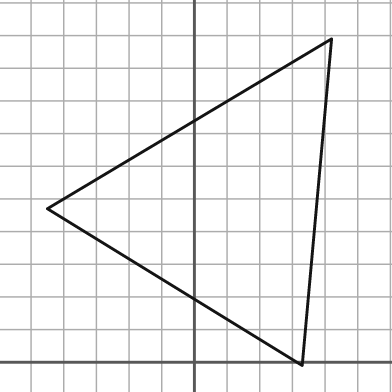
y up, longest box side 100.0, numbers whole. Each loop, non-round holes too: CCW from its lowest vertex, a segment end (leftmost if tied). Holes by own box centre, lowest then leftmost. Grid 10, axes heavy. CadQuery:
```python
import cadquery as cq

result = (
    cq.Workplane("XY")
    .moveTo(33.0, -1.0)
    .lineTo(42.0, 99.0)
    .lineTo(-45.0, 47.0)
    .close()
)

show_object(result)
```